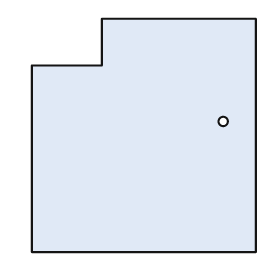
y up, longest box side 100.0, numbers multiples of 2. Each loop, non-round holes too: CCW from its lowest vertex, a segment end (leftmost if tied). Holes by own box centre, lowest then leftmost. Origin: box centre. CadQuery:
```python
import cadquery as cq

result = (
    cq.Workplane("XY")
    .moveTo(-48.0, -50.0)
    .lineTo(48.0, -50.0)
    .lineTo(48.0, 50.0)
    .lineTo(-18.0, 50.0)
    .lineTo(-18.0, 30.0)
    .lineTo(-48.0, 30.0)
    .close()
    .moveTo(34.0, 6.0)
    .circle(2.0)
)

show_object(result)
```